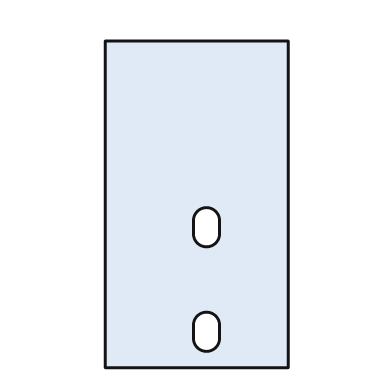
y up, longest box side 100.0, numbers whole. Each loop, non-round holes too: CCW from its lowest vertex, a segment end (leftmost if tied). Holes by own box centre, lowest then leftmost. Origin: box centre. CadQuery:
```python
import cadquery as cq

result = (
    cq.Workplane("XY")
    .moveTo(-28.0, -50.0)
    .lineTo(28.0, -50.0)
    .lineTo(28.0, 50.0)
    .lineTo(-28.0, 50.0)
    .close()
    .moveTo(-1.0, -41.0)
    .threePointArc((3.0, -45.0), (7.0, -41.0))
    .lineTo(7.0, -37.0)
    .threePointArc((3.0, -33.0), (-1.0, -37.0))
    .close()
    .moveTo(-1.0, -9.0)
    .threePointArc((3.0, -13.0), (7.0, -9.0))
    .lineTo(7.0, -5.0)
    .threePointArc((3.0, -1.0), (-1.0, -5.0))
    .close()
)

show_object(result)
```